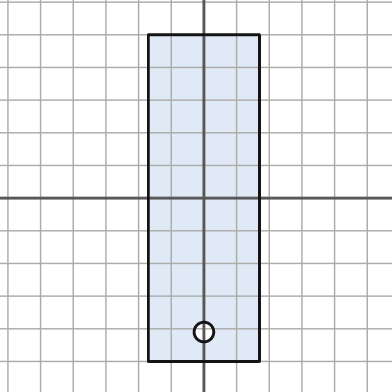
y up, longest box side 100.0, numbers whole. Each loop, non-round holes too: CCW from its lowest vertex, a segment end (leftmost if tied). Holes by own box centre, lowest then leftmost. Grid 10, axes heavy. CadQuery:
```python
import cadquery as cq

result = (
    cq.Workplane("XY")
    .moveTo(-17.0, -50.0)
    .lineTo(17.0, -50.0)
    .lineTo(17.0, 50.0)
    .lineTo(-17.0, 50.0)
    .close()
    .moveTo(0.0, -41.0)
    .circle(3.0)
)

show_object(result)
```